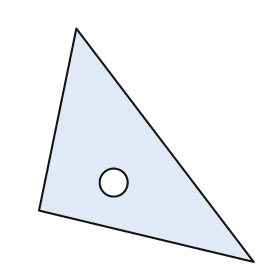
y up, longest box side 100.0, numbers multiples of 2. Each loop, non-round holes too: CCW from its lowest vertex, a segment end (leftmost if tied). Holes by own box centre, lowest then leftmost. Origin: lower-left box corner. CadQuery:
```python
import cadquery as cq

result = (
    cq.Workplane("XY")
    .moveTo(92.0, 0.0)
    .lineTo(16.0, 100.0)
    .lineTo(0.0, 22.0)
    .close()
    .moveTo(32.0, 34.0)
    .circle(6.0)
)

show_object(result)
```